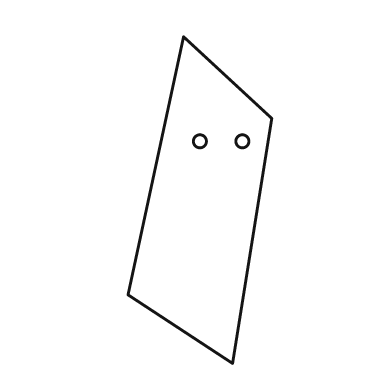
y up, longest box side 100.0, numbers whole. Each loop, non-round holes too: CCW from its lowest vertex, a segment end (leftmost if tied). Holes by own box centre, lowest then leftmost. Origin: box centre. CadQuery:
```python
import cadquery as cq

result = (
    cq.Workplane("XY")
    .moveTo(10.0, -50.0)
    .lineTo(22.0, 25.0)
    .lineTo(-5.0, 50.0)
    .lineTo(-22.0, -29.0)
    .close()
    .moveTo(0.0, 18.0)
    .circle(2.0)
    .moveTo(13.0, 18.0)
    .circle(2.0)
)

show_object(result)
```